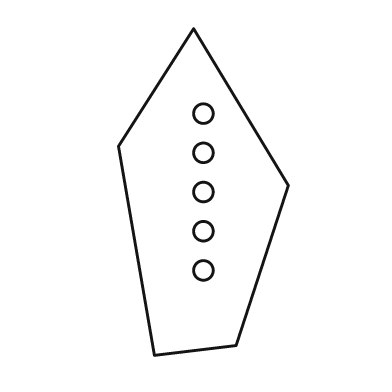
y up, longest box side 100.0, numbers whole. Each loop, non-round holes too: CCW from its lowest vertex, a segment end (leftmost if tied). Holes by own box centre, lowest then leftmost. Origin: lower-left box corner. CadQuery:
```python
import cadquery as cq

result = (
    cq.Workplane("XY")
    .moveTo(11.0, 0.0)
    .lineTo(36.0, 3.0)
    .lineTo(52.0, 52.0)
    .lineTo(23.0, 100.0)
    .lineTo(0.0, 64.0)
    .close()
    .moveTo(26.0, 26.0)
    .circle(3.0)
    .moveTo(26.0, 38.0)
    .circle(3.0)
    .moveTo(26.0, 50.0)
    .circle(3.0)
    .moveTo(26.0, 62.0)
    .circle(3.0)
    .moveTo(26.0, 74.0)
    .circle(3.0)
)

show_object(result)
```